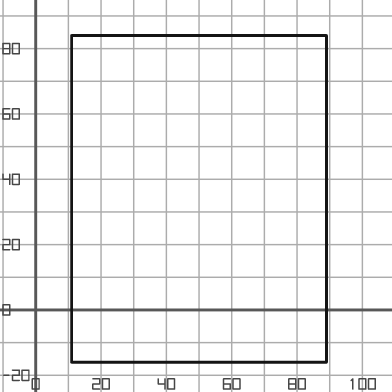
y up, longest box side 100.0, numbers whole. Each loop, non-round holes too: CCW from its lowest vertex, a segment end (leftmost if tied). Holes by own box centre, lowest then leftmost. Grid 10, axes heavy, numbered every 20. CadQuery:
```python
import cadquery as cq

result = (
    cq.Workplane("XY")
    .moveTo(11.0, -16.0)
    .lineTo(89.0, -16.0)
    .lineTo(89.0, 84.0)
    .lineTo(11.0, 84.0)
    .close()
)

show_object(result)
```